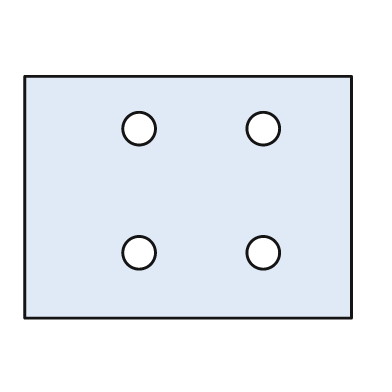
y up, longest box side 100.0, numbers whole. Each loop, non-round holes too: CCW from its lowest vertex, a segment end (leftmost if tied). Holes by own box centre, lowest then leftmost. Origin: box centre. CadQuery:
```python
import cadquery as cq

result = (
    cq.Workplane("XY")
    .moveTo(-50.0, -37.0)
    .lineTo(50.0, -37.0)
    .lineTo(50.0, 37.0)
    .lineTo(-50.0, 37.0)
    .close()
    .moveTo(-15.0, -17.0)
    .circle(5.0)
    .moveTo(23.0, -17.0)
    .circle(5.0)
    .moveTo(-15.0, 21.0)
    .circle(5.0)
    .moveTo(23.0, 21.0)
    .circle(5.0)
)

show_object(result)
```